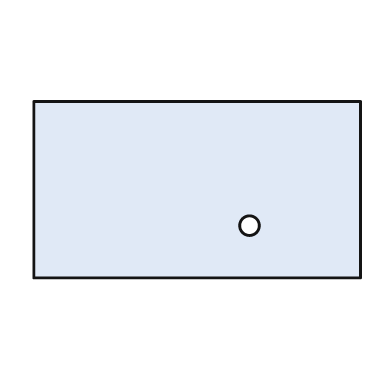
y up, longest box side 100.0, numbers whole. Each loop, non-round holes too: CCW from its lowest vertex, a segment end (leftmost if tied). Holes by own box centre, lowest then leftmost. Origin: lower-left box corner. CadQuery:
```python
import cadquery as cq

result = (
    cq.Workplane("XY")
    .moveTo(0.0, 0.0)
    .lineTo(100.0, 0.0)
    .lineTo(100.0, 54.0)
    .lineTo(0.0, 54.0)
    .close()
    .moveTo(66.0, 16.0)
    .circle(3.0)
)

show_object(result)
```